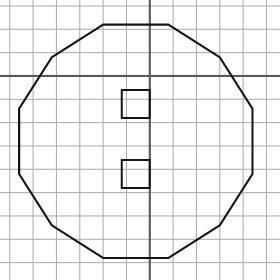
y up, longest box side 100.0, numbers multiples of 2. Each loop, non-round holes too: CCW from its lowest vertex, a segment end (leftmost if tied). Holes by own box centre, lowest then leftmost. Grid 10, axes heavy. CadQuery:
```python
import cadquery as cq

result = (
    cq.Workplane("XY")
    .moveTo(-20.0, -78.0)
    .lineTo(8.0, -78.0)
    .lineTo(30.0, -64.0)
    .lineTo(44.0, -42.0)
    .lineTo(44.0, -14.0)
    .lineTo(30.0, 8.0)
    .lineTo(8.0, 22.0)
    .lineTo(-20.0, 22.0)
    .lineTo(-42.0, 8.0)
    .lineTo(-56.0, -14.0)
    .lineTo(-56.0, -42.0)
    .lineTo(-42.0, -64.0)
    .close()
    .moveTo(-12.0, -48.0)
    .lineTo(0.0, -48.0)
    .lineTo(0.0, -36.0)
    .lineTo(-12.0, -36.0)
    .close()
    .moveTo(-12.0, -18.0)
    .lineTo(0.0, -18.0)
    .lineTo(0.0, -6.0)
    .lineTo(-12.0, -6.0)
    .close()
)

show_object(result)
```